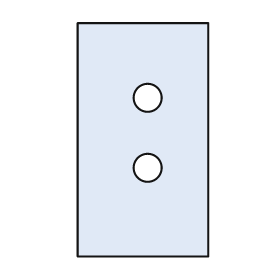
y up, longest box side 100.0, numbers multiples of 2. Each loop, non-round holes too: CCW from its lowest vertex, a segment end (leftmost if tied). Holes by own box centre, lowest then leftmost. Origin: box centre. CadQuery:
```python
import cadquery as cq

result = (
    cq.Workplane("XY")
    .moveTo(-28.0, -50.0)
    .lineTo(28.0, -50.0)
    .lineTo(28.0, 50.0)
    .lineTo(-28.0, 50.0)
    .close()
    .moveTo(2.0, -12.0)
    .circle(6.0)
    .moveTo(2.0, 18.0)
    .circle(6.0)
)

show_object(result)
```